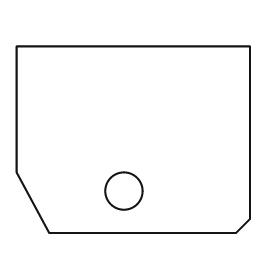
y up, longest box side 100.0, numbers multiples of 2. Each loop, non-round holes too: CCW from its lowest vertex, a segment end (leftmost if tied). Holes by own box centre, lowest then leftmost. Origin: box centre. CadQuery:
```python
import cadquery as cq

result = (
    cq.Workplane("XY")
    .moveTo(-36.0, -40.0)
    .lineTo(44.0, -40.0)
    .lineTo(50.0, -34.0)
    .lineTo(50.0, 40.0)
    .lineTo(-50.0, 40.0)
    .lineTo(-50.0, -14.0)
    .close()
    .moveTo(-4.0, -22.0)
    .circle(8.0)
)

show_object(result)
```